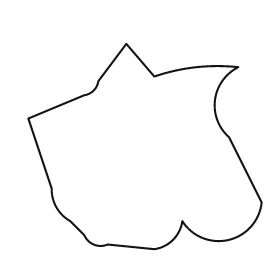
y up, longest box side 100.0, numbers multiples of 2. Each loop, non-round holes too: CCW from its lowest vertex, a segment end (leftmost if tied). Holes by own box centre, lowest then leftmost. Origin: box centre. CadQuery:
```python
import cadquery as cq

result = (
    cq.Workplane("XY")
    .moveTo(4.0, -44.0)
    .threePointArc((12.0, -40.0), (16.0, -32.0))
    .threePointArc((36.0, -40.0), (50.0, -24.0))
    .lineTo(36.0, 4.0)
    .threePointArc((30.0, 20.0), (40.0, 34.0))
    .threePointArc((22.0, 34.0), (4.0, 30.0))
    .lineTo(-8.0, 44.0)
    .lineTo(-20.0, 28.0)
    .threePointArc((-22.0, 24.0), (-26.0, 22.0))
    .lineTo(-50.0, 12.0)
    .lineTo(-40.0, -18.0)
    .threePointArc((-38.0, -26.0), (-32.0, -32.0))
    .lineTo(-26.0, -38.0)
    .threePointArc((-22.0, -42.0), (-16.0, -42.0))
    .close()
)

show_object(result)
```